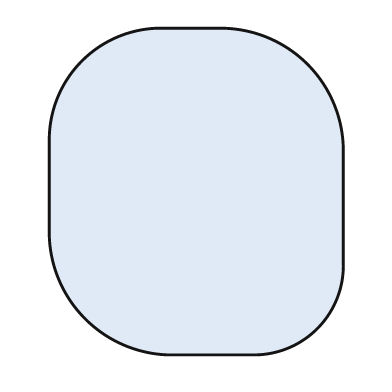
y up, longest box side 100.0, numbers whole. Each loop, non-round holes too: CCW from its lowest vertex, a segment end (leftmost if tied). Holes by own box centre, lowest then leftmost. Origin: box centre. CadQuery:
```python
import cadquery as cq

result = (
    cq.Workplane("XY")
    .moveTo(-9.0, -50.0)
    .lineTo(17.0, -50.0)
    .threePointArc((37.0, -42.0), (45.0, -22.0))
    .lineTo(45.0, 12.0)
    .threePointArc((34.0, 39.0), (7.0, 50.0))
    .lineTo(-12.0, 50.0)
    .threePointArc((-35.0, 40.0), (-45.0, 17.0))
    .lineTo(-45.0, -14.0)
    .threePointArc((-34.0, -39.0), (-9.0, -50.0))
    .close()
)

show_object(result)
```